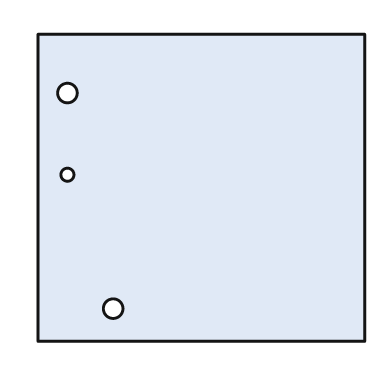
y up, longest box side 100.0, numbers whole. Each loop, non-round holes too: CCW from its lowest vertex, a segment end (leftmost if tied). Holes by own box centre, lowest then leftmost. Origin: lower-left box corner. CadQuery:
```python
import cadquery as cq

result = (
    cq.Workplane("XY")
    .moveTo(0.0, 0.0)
    .lineTo(100.0, 0.0)
    .lineTo(100.0, 94.0)
    .lineTo(0.0, 94.0)
    .close()
    .moveTo(23.0, 10.0)
    .circle(3.0)
    .moveTo(9.0, 51.0)
    .circle(2.0)
    .moveTo(9.0, 76.0)
    .circle(3.0)
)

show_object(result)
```